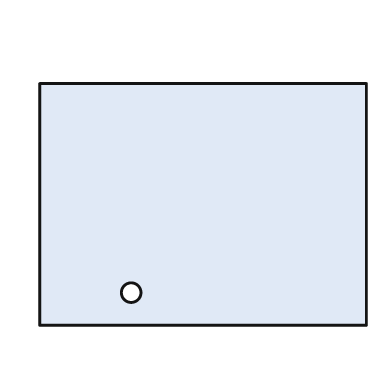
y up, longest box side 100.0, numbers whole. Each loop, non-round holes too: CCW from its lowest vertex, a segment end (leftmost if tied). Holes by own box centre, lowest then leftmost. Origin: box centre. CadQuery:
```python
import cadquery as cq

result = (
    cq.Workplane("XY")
    .moveTo(-50.0, -37.0)
    .lineTo(50.0, -37.0)
    .lineTo(50.0, 37.0)
    .lineTo(-50.0, 37.0)
    .close()
    .moveTo(-22.0, -27.0)
    .circle(3.0)
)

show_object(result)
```